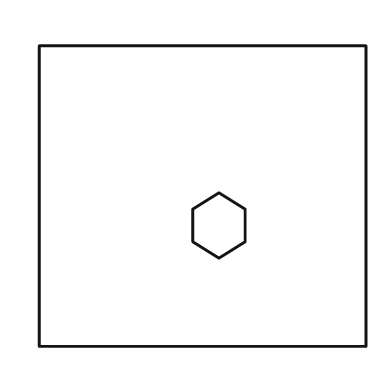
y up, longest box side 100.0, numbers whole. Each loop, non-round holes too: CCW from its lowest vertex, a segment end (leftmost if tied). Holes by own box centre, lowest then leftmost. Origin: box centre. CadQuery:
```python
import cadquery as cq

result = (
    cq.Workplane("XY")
    .moveTo(-50.0, -46.0)
    .lineTo(50.0, -46.0)
    .lineTo(50.0, 46.0)
    .lineTo(-50.0, 46.0)
    .close()
    .moveTo(5.0, -19.0)
    .lineTo(13.0, -14.0)
    .lineTo(13.0, -4.0)
    .lineTo(5.0, 1.0)
    .lineTo(-3.0, -4.0)
    .lineTo(-3.0, -14.0)
    .close()
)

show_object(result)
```